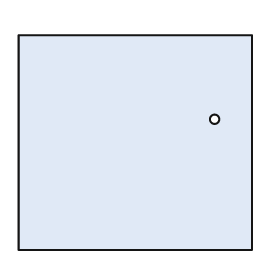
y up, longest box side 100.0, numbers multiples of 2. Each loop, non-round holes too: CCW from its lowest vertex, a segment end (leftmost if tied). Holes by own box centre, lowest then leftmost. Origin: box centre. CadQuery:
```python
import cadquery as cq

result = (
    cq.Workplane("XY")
    .moveTo(-50.0, -46.0)
    .lineTo(50.0, -46.0)
    .lineTo(50.0, 46.0)
    .lineTo(-50.0, 46.0)
    .close()
    .moveTo(34.0, 10.0)
    .circle(2.0)
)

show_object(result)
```